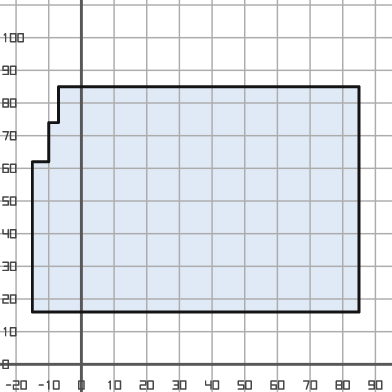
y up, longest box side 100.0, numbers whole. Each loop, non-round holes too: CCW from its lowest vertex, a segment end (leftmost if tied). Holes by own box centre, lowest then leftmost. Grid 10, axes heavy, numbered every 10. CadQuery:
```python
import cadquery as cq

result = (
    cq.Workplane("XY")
    .moveTo(-15.0, 16.0)
    .lineTo(85.0, 16.0)
    .lineTo(85.0, 85.0)
    .lineTo(-7.0, 85.0)
    .lineTo(-7.0, 74.0)
    .lineTo(-10.0, 74.0)
    .lineTo(-10.0, 62.0)
    .lineTo(-15.0, 62.0)
    .close()
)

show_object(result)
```